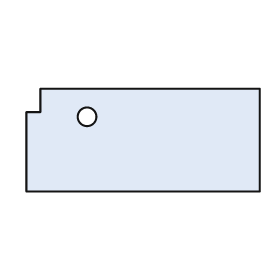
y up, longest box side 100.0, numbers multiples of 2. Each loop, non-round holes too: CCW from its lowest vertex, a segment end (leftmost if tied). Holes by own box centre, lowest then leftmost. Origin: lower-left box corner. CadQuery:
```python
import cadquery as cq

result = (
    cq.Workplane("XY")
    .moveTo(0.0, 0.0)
    .lineTo(100.0, 0.0)
    .lineTo(100.0, 44.0)
    .lineTo(6.0, 44.0)
    .lineTo(6.0, 34.0)
    .lineTo(0.0, 34.0)
    .close()
    .moveTo(26.0, 32.0)
    .circle(4.0)
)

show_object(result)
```